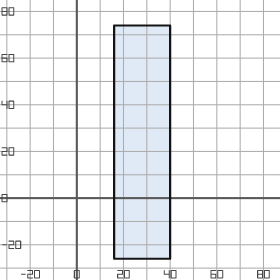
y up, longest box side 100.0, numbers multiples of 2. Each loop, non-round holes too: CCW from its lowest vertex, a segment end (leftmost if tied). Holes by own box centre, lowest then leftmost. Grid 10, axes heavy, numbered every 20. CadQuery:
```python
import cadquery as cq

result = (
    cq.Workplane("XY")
    .moveTo(16.0, -26.0)
    .lineTo(40.0, -26.0)
    .lineTo(40.0, 74.0)
    .lineTo(16.0, 74.0)
    .close()
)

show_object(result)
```